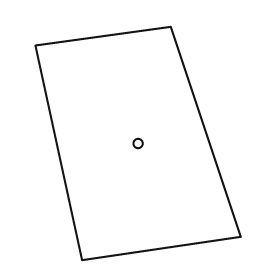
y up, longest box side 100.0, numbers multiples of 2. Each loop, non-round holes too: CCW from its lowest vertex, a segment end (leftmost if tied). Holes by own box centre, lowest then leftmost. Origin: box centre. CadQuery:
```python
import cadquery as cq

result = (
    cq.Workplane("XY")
    .moveTo(-24.0, -50.0)
    .lineTo(44.0, -40.0)
    .lineTo(14.0, 50.0)
    .lineTo(-44.0, 42.0)
    .close()
    .moveTo(0.0, 0.0)
    .circle(2.0)
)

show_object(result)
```